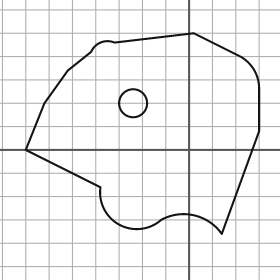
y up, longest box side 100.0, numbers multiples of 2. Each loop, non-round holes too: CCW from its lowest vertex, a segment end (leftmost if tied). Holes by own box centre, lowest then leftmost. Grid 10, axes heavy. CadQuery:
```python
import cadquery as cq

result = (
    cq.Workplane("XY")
    .moveTo(14.0, -36.0)
    .lineTo(30.0, 8.0)
    .lineTo(30.0, 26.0)
    .threePointArc((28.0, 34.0), (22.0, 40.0))
    .lineTo(2.0, 50.0)
    .lineTo(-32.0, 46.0)
    .threePointArc((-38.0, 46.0), (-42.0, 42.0))
    .lineTo(-52.0, 34.0)
    .lineTo(-62.0, 20.0)
    .lineTo(-70.0, 0.0)
    .lineTo(-38.0, -16.0)
    .threePointArc((-30.0, -32.0), (-12.0, -30.0))
    .threePointArc((2.0, -28.0), (14.0, -36.0))
    .close()
    .moveTo(-24.0, 20.0)
    .circle(6.0)
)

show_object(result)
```